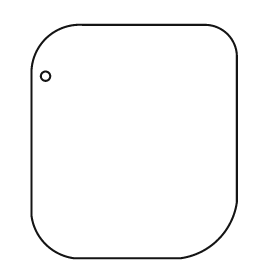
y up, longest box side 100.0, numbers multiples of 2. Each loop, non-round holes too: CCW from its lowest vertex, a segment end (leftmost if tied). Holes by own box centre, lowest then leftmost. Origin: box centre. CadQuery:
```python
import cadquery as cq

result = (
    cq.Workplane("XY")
    .moveTo(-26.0, -50.0)
    .lineTo(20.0, -50.0)
    .threePointArc((36.0, -42.0), (44.0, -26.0))
    .lineTo(44.0, 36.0)
    .threePointArc((40.0, 46.0), (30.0, 50.0))
    .lineTo(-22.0, 50.0)
    .threePointArc((-38.0, 44.0), (-44.0, 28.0))
    .lineTo(-44.0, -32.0)
    .threePointArc((-38.0, -44.0), (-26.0, -50.0))
    .close()
    .moveTo(-38.0, 28.0)
    .circle(2.0)
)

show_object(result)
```